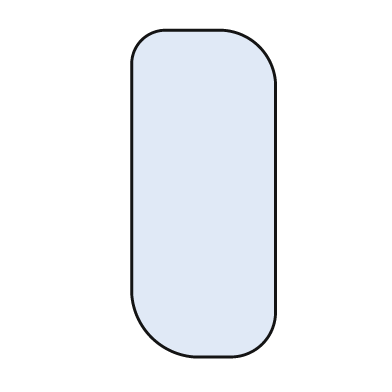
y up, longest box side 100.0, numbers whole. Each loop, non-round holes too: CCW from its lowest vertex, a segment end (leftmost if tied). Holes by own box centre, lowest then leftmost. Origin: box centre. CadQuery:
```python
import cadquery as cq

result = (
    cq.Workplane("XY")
    .moveTo(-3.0, -50.0)
    .lineTo(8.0, -50.0)
    .threePointArc((18.0, -46.0), (22.0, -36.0))
    .lineTo(22.0, 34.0)
    .threePointArc((17.0, 45.0), (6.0, 50.0))
    .lineTo(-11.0, 50.0)
    .threePointArc((-19.0, 47.0), (-22.0, 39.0))
    .lineTo(-22.0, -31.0)
    .threePointArc((-16.0, -44.0), (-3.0, -50.0))
    .close()
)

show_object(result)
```